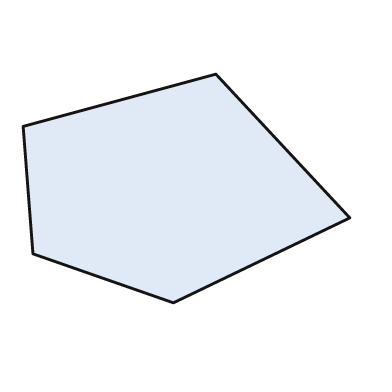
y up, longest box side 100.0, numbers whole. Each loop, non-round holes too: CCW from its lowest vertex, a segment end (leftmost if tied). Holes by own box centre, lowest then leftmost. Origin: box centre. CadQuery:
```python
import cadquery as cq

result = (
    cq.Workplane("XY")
    .moveTo(-4.0, -35.0)
    .lineTo(50.0, -9.0)
    .lineTo(9.0, 35.0)
    .lineTo(-50.0, 19.0)
    .lineTo(-47.0, -20.0)
    .close()
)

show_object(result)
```